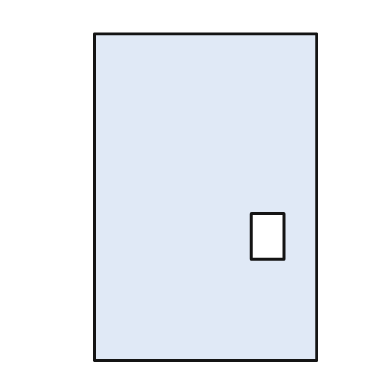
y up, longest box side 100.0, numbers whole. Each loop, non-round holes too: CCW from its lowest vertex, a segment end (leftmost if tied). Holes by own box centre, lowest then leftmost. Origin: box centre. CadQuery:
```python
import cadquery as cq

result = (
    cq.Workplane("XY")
    .moveTo(-34.0, -50.0)
    .lineTo(34.0, -50.0)
    .lineTo(34.0, 50.0)
    .lineTo(-34.0, 50.0)
    .close()
    .moveTo(14.0, -19.0)
    .lineTo(24.0, -19.0)
    .lineTo(24.0, -5.0)
    .lineTo(14.0, -5.0)
    .close()
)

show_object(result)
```